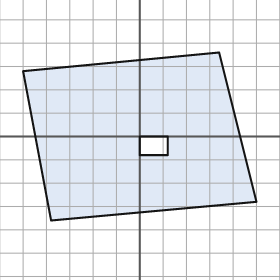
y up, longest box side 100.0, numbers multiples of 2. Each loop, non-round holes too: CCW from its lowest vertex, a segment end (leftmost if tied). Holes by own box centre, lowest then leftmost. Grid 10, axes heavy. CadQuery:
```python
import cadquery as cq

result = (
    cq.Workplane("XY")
    .moveTo(-38.0, -36.0)
    .lineTo(50.0, -28.0)
    .lineTo(34.0, 36.0)
    .lineTo(-50.0, 28.0)
    .close()
    .moveTo(0.0, -8.0)
    .lineTo(12.0, -8.0)
    .lineTo(12.0, 0.0)
    .lineTo(0.0, 0.0)
    .close()
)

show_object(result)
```